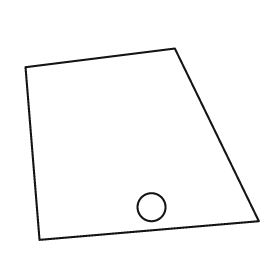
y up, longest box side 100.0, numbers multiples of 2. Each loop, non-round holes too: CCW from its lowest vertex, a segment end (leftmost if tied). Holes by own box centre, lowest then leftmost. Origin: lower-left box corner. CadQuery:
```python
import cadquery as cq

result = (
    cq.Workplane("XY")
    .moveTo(6.0, 0.0)
    .lineTo(100.0, 8.0)
    .lineTo(64.0, 82.0)
    .lineTo(0.0, 74.0)
    .close()
    .moveTo(54.0, 14.0)
    .circle(6.0)
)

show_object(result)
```